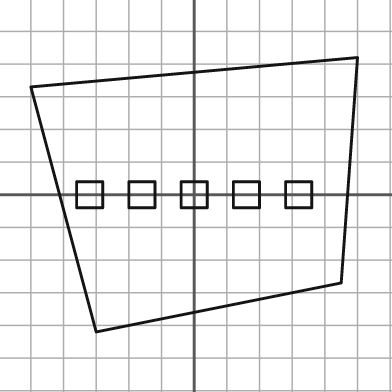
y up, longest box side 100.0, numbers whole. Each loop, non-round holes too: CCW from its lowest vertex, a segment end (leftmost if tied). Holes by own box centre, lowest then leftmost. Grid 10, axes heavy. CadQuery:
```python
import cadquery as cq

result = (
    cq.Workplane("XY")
    .moveTo(-30.0, -42.0)
    .lineTo(45.0, -27.0)
    .lineTo(50.0, 42.0)
    .lineTo(-50.0, 33.0)
    .close()
    .moveTo(-36.0, -4.0)
    .lineTo(-28.0, -4.0)
    .lineTo(-28.0, 4.0)
    .lineTo(-36.0, 4.0)
    .close()
    .moveTo(-20.0, -4.0)
    .lineTo(-12.0, -4.0)
    .lineTo(-12.0, 4.0)
    .lineTo(-20.0, 4.0)
    .close()
    .moveTo(-4.0, -4.0)
    .lineTo(4.0, -4.0)
    .lineTo(4.0, 4.0)
    .lineTo(-4.0, 4.0)
    .close()
    .moveTo(12.0, -4.0)
    .lineTo(20.0, -4.0)
    .lineTo(20.0, 4.0)
    .lineTo(12.0, 4.0)
    .close()
    .moveTo(28.0, -4.0)
    .lineTo(36.0, -4.0)
    .lineTo(36.0, 4.0)
    .lineTo(28.0, 4.0)
    .close()
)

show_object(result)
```